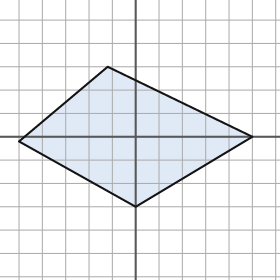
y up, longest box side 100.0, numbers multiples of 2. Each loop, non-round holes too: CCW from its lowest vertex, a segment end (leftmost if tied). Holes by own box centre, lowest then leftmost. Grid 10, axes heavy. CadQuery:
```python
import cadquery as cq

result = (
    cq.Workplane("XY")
    .moveTo(0.0, -30.0)
    .lineTo(50.0, 0.0)
    .lineTo(-12.0, 30.0)
    .lineTo(-50.0, -2.0)
    .close()
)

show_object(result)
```